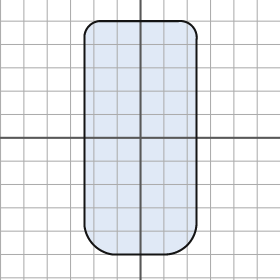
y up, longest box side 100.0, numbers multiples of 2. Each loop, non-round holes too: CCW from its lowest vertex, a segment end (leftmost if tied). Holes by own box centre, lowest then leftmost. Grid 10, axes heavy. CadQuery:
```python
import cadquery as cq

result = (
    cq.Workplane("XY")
    .moveTo(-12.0, -50.0)
    .lineTo(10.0, -50.0)
    .threePointArc((20.0, -46.0), (24.0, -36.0))
    .lineTo(24.0, 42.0)
    .threePointArc((22.0, 48.0), (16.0, 50.0))
    .lineTo(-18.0, 50.0)
    .threePointArc((-22.0, 48.0), (-24.0, 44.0))
    .lineTo(-24.0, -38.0)
    .threePointArc((-20.0, -46.0), (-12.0, -50.0))
    .close()
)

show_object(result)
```